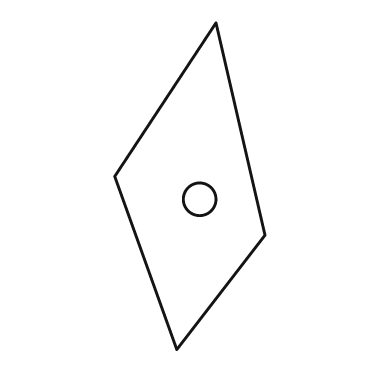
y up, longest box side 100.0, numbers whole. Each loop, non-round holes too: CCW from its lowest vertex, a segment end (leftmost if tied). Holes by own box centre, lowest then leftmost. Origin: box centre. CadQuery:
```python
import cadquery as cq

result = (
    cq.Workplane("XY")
    .moveTo(-4.0, -50.0)
    .lineTo(23.0, -15.0)
    .lineTo(8.0, 50.0)
    .lineTo(-23.0, 3.0)
    .close()
    .moveTo(3.0, -4.0)
    .circle(5.0)
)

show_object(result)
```